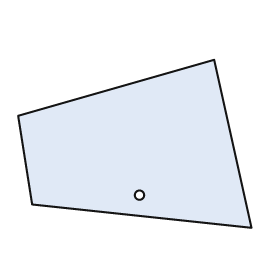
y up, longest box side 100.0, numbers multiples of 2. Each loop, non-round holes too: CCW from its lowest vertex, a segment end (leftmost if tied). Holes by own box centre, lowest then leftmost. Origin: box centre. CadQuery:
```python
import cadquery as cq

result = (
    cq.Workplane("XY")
    .moveTo(50.0, -36.0)
    .lineTo(34.0, 36.0)
    .lineTo(-50.0, 12.0)
    .lineTo(-44.0, -26.0)
    .close()
    .moveTo(2.0, -22.0)
    .circle(2.0)
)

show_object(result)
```